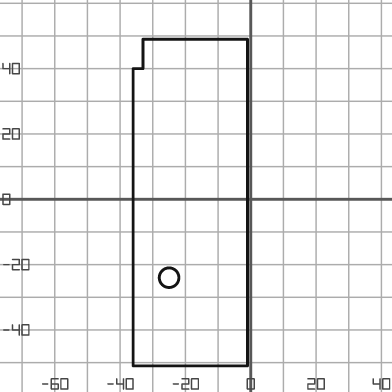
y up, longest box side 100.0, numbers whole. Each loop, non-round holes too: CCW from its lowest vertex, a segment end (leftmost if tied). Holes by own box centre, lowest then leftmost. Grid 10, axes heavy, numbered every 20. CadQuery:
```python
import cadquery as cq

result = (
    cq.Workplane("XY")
    .moveTo(-36.0, -51.0)
    .lineTo(-1.0, -51.0)
    .lineTo(-1.0, 49.0)
    .lineTo(-33.0, 49.0)
    .lineTo(-33.0, 40.0)
    .lineTo(-36.0, 40.0)
    .close()
    .moveTo(-25.0, -24.0)
    .circle(3.0)
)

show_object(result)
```